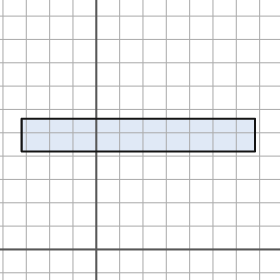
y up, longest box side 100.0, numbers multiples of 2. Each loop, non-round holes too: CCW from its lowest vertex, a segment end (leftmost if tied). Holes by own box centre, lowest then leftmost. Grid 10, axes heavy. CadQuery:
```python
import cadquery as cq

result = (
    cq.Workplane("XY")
    .moveTo(-32.0, 42.0)
    .lineTo(68.0, 42.0)
    .lineTo(68.0, 56.0)
    .lineTo(-32.0, 56.0)
    .close()
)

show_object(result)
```